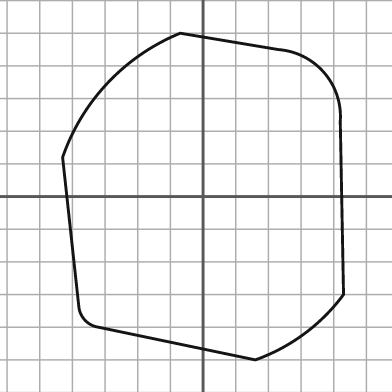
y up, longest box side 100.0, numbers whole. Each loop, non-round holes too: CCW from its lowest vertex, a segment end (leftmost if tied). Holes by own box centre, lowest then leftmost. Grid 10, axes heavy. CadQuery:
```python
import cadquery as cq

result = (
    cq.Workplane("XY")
    .moveTo(16.0, -50.0)
    .threePointArc((31.0, -42.0), (43.0, -30.0))
    .lineTo(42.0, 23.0)
    .threePointArc((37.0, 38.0), (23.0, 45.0))
    .lineTo(-7.0, 50.0)
    .threePointArc((-29.0, 35.0), (-43.0, 12.0))
    .lineTo(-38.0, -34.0)
    .threePointArc((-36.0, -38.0), (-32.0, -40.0))
    .close()
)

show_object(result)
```